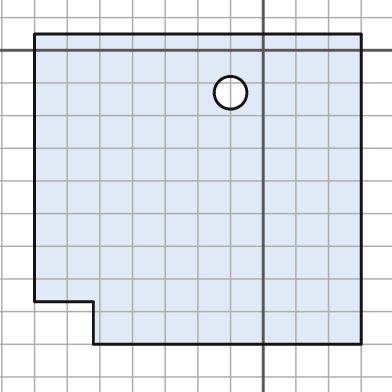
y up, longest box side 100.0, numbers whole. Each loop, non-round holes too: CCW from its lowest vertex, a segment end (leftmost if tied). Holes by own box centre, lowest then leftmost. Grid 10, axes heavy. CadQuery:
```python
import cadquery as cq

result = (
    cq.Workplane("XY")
    .moveTo(-52.0, -90.0)
    .lineTo(30.0, -90.0)
    .lineTo(30.0, 5.0)
    .lineTo(-70.0, 5.0)
    .lineTo(-70.0, -77.0)
    .lineTo(-52.0, -77.0)
    .close()
    .moveTo(-10.0, -13.0)
    .circle(5.0)
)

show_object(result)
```